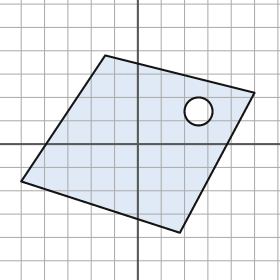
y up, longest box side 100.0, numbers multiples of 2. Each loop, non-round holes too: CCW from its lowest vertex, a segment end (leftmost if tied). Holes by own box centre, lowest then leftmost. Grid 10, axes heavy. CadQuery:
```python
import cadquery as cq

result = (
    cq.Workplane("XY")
    .moveTo(18.0, -38.0)
    .lineTo(50.0, 22.0)
    .lineTo(-14.0, 38.0)
    .lineTo(-50.0, -16.0)
    .close()
    .moveTo(26.0, 14.0)
    .circle(6.0)
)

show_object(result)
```